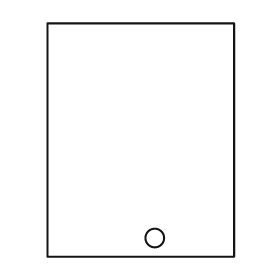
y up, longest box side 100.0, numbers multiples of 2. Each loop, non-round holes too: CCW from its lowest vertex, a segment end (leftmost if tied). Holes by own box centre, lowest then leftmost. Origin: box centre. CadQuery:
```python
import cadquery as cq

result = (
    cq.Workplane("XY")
    .moveTo(-40.0, -50.0)
    .lineTo(40.0, -50.0)
    .lineTo(40.0, 50.0)
    .lineTo(-40.0, 50.0)
    .close()
    .moveTo(6.0, -42.0)
    .circle(4.0)
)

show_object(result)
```